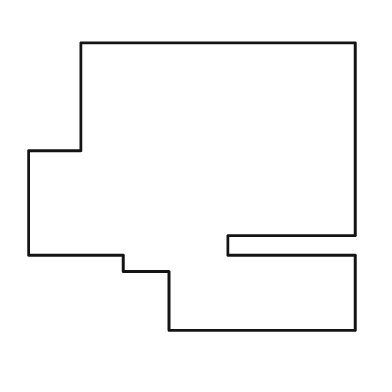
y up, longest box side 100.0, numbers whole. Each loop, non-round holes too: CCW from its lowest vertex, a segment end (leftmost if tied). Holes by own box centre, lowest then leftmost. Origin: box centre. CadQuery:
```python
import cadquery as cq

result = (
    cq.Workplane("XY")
    .moveTo(-7.0, -44.0)
    .lineTo(50.0, -44.0)
    .lineTo(50.0, -21.0)
    .lineTo(11.0, -21.0)
    .lineTo(11.0, -15.0)
    .lineTo(50.0, -15.0)
    .lineTo(50.0, 44.0)
    .lineTo(-34.0, 44.0)
    .lineTo(-34.0, 11.0)
    .lineTo(-50.0, 11.0)
    .lineTo(-50.0, -21.0)
    .lineTo(-21.0, -21.0)
    .lineTo(-21.0, -26.0)
    .lineTo(-7.0, -26.0)
    .close()
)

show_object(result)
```